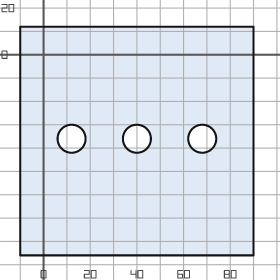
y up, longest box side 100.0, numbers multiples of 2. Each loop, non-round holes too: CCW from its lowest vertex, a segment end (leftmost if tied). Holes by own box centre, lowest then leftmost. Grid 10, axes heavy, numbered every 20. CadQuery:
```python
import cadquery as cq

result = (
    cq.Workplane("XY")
    .moveTo(-10.0, -86.0)
    .lineTo(90.0, -86.0)
    .lineTo(90.0, 12.0)
    .lineTo(-10.0, 12.0)
    .close()
    .moveTo(12.0, -36.0)
    .circle(6.0)
    .moveTo(40.0, -36.0)
    .circle(6.0)
    .moveTo(68.0, -36.0)
    .circle(6.0)
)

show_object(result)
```